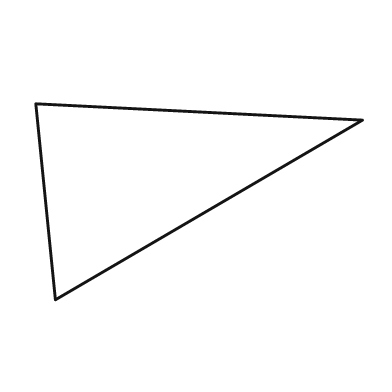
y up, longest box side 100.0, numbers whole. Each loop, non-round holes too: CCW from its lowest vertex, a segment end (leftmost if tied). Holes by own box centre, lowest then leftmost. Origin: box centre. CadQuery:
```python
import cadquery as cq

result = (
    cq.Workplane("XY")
    .moveTo(-44.0, -30.0)
    .lineTo(50.0, 25.0)
    .lineTo(-50.0, 30.0)
    .close()
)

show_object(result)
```